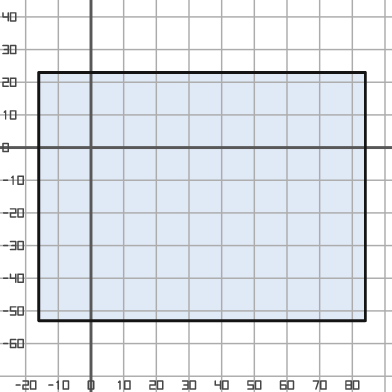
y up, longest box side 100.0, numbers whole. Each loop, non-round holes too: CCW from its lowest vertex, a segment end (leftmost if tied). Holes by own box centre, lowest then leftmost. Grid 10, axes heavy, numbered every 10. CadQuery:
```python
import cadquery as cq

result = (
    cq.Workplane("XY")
    .moveTo(-16.0, -53.0)
    .lineTo(84.0, -53.0)
    .lineTo(84.0, 23.0)
    .lineTo(-16.0, 23.0)
    .close()
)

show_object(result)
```